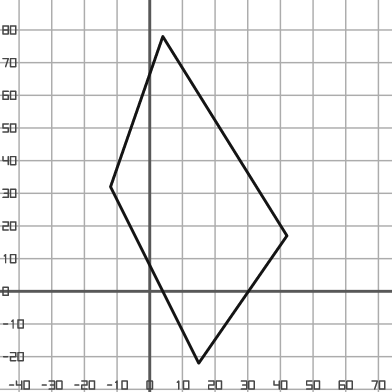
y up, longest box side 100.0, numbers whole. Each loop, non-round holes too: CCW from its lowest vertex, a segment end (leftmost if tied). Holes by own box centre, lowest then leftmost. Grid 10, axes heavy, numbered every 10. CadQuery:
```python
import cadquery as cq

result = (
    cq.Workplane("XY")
    .moveTo(15.0, -22.0)
    .lineTo(42.0, 17.0)
    .lineTo(4.0, 78.0)
    .lineTo(-12.0, 32.0)
    .close()
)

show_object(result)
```